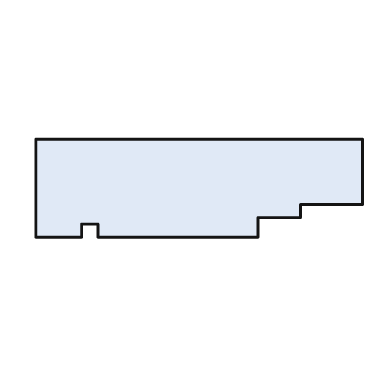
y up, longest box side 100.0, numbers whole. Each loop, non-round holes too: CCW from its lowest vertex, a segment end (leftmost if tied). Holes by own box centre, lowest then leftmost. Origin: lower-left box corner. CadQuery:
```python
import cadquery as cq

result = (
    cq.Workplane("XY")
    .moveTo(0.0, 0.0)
    .lineTo(14.0, 0.0)
    .lineTo(14.0, 4.0)
    .lineTo(19.0, 4.0)
    .lineTo(19.0, 0.0)
    .lineTo(68.0, 0.0)
    .lineTo(68.0, 6.0)
    .lineTo(81.0, 6.0)
    .lineTo(81.0, 10.0)
    .lineTo(100.0, 10.0)
    .lineTo(100.0, 30.0)
    .lineTo(0.0, 30.0)
    .close()
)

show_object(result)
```